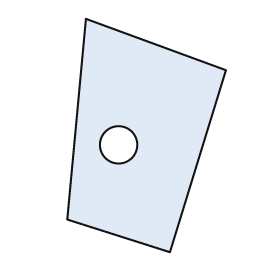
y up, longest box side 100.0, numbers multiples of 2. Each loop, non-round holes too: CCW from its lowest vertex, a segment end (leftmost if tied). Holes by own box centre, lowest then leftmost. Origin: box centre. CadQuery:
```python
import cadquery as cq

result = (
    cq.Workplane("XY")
    .moveTo(10.0, -50.0)
    .lineTo(34.0, 28.0)
    .lineTo(-26.0, 50.0)
    .lineTo(-34.0, -36.0)
    .close()
    .moveTo(-12.0, -4.0)
    .circle(8.0)
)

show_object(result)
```